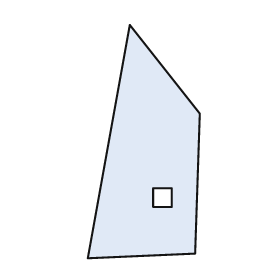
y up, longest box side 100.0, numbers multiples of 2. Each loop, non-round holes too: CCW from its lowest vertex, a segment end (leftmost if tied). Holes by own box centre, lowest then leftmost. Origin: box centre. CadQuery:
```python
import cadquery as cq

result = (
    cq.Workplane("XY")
    .moveTo(-24.0, -50.0)
    .lineTo(22.0, -48.0)
    .lineTo(24.0, 12.0)
    .lineTo(-6.0, 50.0)
    .close()
    .moveTo(4.0, -28.0)
    .lineTo(12.0, -28.0)
    .lineTo(12.0, -20.0)
    .lineTo(4.0, -20.0)
    .close()
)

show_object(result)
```